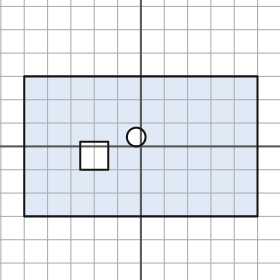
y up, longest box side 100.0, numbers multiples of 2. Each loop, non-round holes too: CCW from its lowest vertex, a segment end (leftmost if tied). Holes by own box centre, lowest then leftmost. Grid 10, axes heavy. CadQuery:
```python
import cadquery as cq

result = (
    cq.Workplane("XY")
    .moveTo(-50.0, -30.0)
    .lineTo(50.0, -30.0)
    .lineTo(50.0, 30.0)
    .lineTo(-50.0, 30.0)
    .close()
    .moveTo(-26.0, -10.0)
    .lineTo(-14.0, -10.0)
    .lineTo(-14.0, 2.0)
    .lineTo(-26.0, 2.0)
    .close()
    .moveTo(-2.0, 4.0)
    .circle(4.0)
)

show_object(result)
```